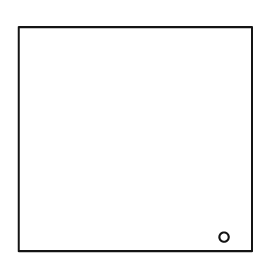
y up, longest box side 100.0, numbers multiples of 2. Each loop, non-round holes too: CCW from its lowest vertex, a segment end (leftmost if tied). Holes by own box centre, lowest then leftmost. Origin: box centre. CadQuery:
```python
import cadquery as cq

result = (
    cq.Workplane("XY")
    .moveTo(-50.0, -48.0)
    .lineTo(50.0, -48.0)
    .lineTo(50.0, 48.0)
    .lineTo(-50.0, 48.0)
    .close()
    .moveTo(38.0, -42.0)
    .circle(2.0)
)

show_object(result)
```